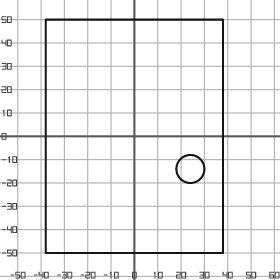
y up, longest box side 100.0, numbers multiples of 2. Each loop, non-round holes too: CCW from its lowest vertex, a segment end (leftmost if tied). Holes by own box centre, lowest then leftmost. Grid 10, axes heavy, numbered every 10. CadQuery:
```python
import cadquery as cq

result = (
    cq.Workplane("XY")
    .moveTo(-38.0, -50.0)
    .lineTo(38.0, -50.0)
    .lineTo(38.0, 50.0)
    .lineTo(-38.0, 50.0)
    .close()
    .moveTo(24.0, -14.0)
    .circle(6.0)
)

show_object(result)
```